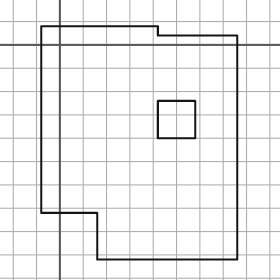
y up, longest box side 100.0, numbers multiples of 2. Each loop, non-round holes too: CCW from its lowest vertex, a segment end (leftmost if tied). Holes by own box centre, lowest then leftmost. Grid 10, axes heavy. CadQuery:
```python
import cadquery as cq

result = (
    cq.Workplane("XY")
    .moveTo(16.0, -92.0)
    .lineTo(76.0, -92.0)
    .lineTo(76.0, 4.0)
    .lineTo(42.0, 4.0)
    .lineTo(42.0, 8.0)
    .lineTo(-8.0, 8.0)
    .lineTo(-8.0, -72.0)
    .lineTo(16.0, -72.0)
    .close()
    .moveTo(42.0, -40.0)
    .lineTo(58.0, -40.0)
    .lineTo(58.0, -24.0)
    .lineTo(42.0, -24.0)
    .close()
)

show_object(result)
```